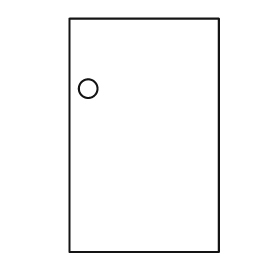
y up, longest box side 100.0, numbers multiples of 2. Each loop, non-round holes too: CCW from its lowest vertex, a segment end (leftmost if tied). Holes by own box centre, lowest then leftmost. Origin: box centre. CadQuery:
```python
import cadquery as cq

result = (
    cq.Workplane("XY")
    .moveTo(-32.0, -50.0)
    .lineTo(32.0, -50.0)
    .lineTo(32.0, 50.0)
    .lineTo(-32.0, 50.0)
    .close()
    .moveTo(-24.0, 20.0)
    .circle(4.0)
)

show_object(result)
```